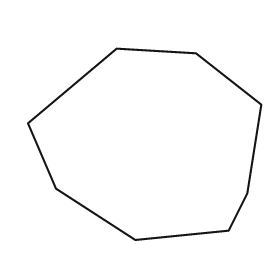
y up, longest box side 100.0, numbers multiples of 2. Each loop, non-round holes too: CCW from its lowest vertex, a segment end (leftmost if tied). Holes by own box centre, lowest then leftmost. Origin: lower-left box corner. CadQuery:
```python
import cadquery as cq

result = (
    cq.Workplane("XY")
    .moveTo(46.0, 0.0)
    .lineTo(86.0, 4.0)
    .lineTo(94.0, 20.0)
    .lineTo(100.0, 58.0)
    .lineTo(72.0, 80.0)
    .lineTo(38.0, 82.0)
    .lineTo(0.0, 50.0)
    .lineTo(12.0, 22.0)
    .close()
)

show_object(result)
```